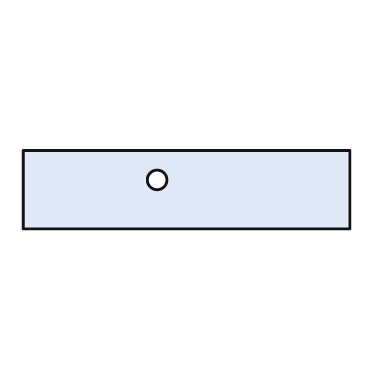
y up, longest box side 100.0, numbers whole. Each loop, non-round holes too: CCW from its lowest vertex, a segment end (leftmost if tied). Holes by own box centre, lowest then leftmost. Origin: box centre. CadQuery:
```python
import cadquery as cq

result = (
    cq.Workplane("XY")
    .moveTo(-50.0, -12.0)
    .lineTo(50.0, -12.0)
    .lineTo(50.0, 12.0)
    .lineTo(-50.0, 12.0)
    .close()
    .moveTo(-9.0, 3.0)
    .circle(3.0)
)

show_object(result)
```